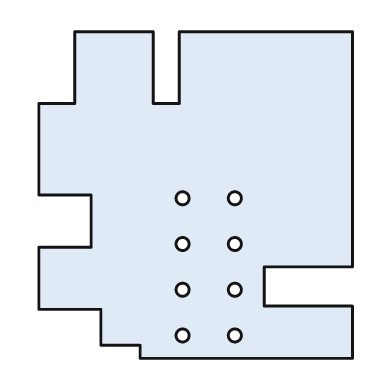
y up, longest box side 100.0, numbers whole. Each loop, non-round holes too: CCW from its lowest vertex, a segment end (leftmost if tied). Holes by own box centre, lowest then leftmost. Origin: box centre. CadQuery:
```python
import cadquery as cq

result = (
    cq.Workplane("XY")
    .moveTo(-17.0, -50.0)
    .lineTo(48.0, -50.0)
    .lineTo(48.0, -34.0)
    .lineTo(21.0, -34.0)
    .lineTo(21.0, -22.0)
    .lineTo(48.0, -22.0)
    .lineTo(48.0, 50.0)
    .lineTo(-5.0, 50.0)
    .lineTo(-5.0, 28.0)
    .lineTo(-13.0, 28.0)
    .lineTo(-13.0, 50.0)
    .lineTo(-37.0, 50.0)
    .lineTo(-37.0, 28.0)
    .lineTo(-48.0, 28.0)
    .lineTo(-48.0, 0.0)
    .lineTo(-32.0, 0.0)
    .lineTo(-32.0, -16.0)
    .lineTo(-48.0, -16.0)
    .lineTo(-48.0, -35.0)
    .lineTo(-29.0, -35.0)
    .lineTo(-29.0, -46.0)
    .lineTo(-17.0, -46.0)
    .close()
    .moveTo(-4.0, -43.0)
    .circle(2.0)
    .moveTo(12.0, -43.0)
    .circle(2.0)
    .moveTo(-4.0, -29.0)
    .circle(2.0)
    .moveTo(12.0, -29.0)
    .circle(2.0)
    .moveTo(-4.0, -15.0)
    .circle(2.0)
    .moveTo(12.0, -15.0)
    .circle(2.0)
    .moveTo(-4.0, -1.0)
    .circle(2.0)
    .moveTo(12.0, -1.0)
    .circle(2.0)
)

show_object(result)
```